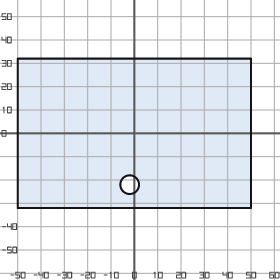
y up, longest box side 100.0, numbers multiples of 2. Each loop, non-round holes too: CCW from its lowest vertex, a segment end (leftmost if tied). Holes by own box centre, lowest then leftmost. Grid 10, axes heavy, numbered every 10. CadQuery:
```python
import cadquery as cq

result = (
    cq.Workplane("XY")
    .moveTo(-50.0, -32.0)
    .lineTo(50.0, -32.0)
    .lineTo(50.0, 32.0)
    .lineTo(-50.0, 32.0)
    .close()
    .moveTo(-2.0, -22.0)
    .circle(4.0)
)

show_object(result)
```